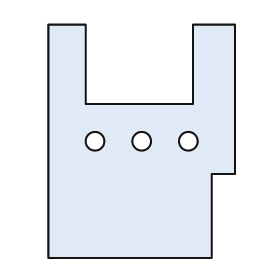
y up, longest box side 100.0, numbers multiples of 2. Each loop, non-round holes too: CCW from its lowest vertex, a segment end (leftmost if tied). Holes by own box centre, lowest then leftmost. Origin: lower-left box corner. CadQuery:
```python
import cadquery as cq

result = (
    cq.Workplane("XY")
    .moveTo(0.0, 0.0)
    .lineTo(70.0, 0.0)
    .lineTo(70.0, 36.0)
    .lineTo(80.0, 36.0)
    .lineTo(80.0, 100.0)
    .lineTo(62.0, 100.0)
    .lineTo(62.0, 66.0)
    .lineTo(16.0, 66.0)
    .lineTo(16.0, 100.0)
    .lineTo(0.0, 100.0)
    .close()
    .moveTo(20.0, 50.0)
    .circle(4.0)
    .moveTo(40.0, 50.0)
    .circle(4.0)
    .moveTo(60.0, 50.0)
    .circle(4.0)
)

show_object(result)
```